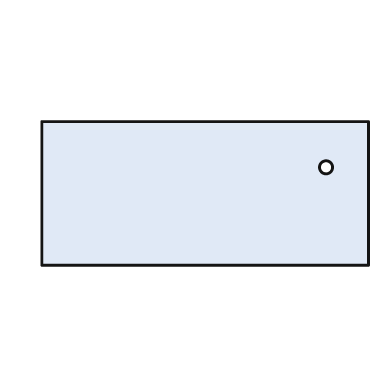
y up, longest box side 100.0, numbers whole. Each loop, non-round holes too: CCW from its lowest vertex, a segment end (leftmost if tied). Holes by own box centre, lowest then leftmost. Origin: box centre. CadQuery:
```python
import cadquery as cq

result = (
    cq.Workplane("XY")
    .moveTo(-50.0, -22.0)
    .lineTo(50.0, -22.0)
    .lineTo(50.0, 22.0)
    .lineTo(-50.0, 22.0)
    .close()
    .moveTo(37.0, 8.0)
    .circle(2.0)
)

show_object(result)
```